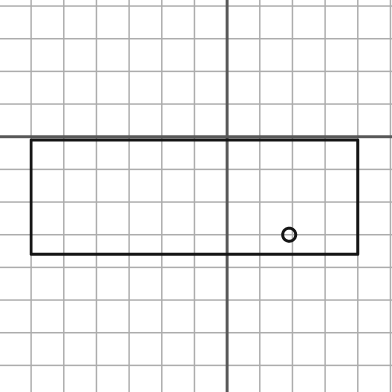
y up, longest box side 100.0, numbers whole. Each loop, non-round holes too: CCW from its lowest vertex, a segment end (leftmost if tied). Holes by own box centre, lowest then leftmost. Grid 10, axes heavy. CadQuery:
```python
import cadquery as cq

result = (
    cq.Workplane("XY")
    .moveTo(-60.0, -36.0)
    .lineTo(40.0, -36.0)
    .lineTo(40.0, -1.0)
    .lineTo(-60.0, -1.0)
    .close()
    .moveTo(19.0, -30.0)
    .circle(2.0)
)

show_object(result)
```